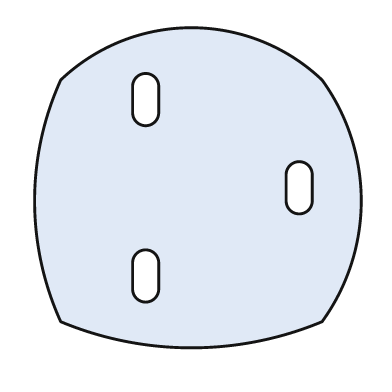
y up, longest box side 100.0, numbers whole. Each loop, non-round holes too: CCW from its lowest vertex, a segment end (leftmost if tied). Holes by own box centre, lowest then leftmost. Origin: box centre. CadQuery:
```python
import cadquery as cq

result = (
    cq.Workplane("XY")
    .moveTo(-42.0, -41.0)
    .threePointArc((-2.0, -49.0), (38.0, -41.0))
    .threePointArc((50.0, -4.0), (38.0, 33.0))
    .threePointArc((-2.0, 49.0), (-42.0, 33.0))
    .threePointArc((-50.0, -4.0), (-42.0, -41.0))
    .close()
    .moveTo(-20.0, -31.0)
    .threePointArc((-16.0, -35.0), (-12.0, -31.0))
    .lineTo(-12.0, -23.0)
    .threePointArc((-16.0, -19.0), (-20.0, -23.0))
    .close()
    .moveTo(27.0, -4.0)
    .threePointArc((31.0, -8.0), (35.0, -4.0))
    .lineTo(35.0, 4.0)
    .threePointArc((31.0, 8.0), (27.0, 4.0))
    .close()
    .moveTo(-20.0, 23.0)
    .threePointArc((-16.0, 19.0), (-12.0, 23.0))
    .lineTo(-12.0, 31.0)
    .threePointArc((-16.0, 35.0), (-20.0, 31.0))
    .close()
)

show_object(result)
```